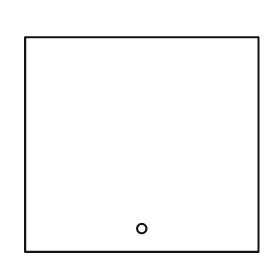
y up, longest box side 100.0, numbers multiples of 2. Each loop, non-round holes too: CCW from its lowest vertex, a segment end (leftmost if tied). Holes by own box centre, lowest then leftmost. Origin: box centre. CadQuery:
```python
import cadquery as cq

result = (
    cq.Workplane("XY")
    .moveTo(-50.0, -46.0)
    .lineTo(50.0, -46.0)
    .lineTo(50.0, 46.0)
    .lineTo(-50.0, 46.0)
    .close()
    .moveTo(0.0, -36.0)
    .circle(2.0)
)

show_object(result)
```